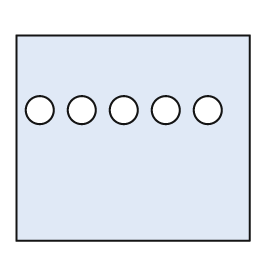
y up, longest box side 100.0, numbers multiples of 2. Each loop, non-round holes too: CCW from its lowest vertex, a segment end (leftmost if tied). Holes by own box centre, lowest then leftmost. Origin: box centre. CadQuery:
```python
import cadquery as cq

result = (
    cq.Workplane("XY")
    .moveTo(-50.0, -44.0)
    .lineTo(50.0, -44.0)
    .lineTo(50.0, 44.0)
    .lineTo(-50.0, 44.0)
    .close()
    .moveTo(-40.0, 12.0)
    .circle(6.0)
    .moveTo(-22.0, 12.0)
    .circle(6.0)
    .moveTo(-4.0, 12.0)
    .circle(6.0)
    .moveTo(14.0, 12.0)
    .circle(6.0)
    .moveTo(32.0, 12.0)
    .circle(6.0)
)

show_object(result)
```